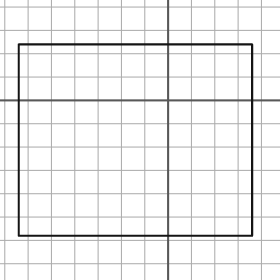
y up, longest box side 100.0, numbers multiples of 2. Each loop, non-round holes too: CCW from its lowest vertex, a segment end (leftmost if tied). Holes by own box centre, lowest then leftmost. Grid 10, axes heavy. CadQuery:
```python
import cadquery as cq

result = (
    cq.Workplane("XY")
    .moveTo(-64.0, -58.0)
    .lineTo(36.0, -58.0)
    .lineTo(36.0, 24.0)
    .lineTo(-64.0, 24.0)
    .close()
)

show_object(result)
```